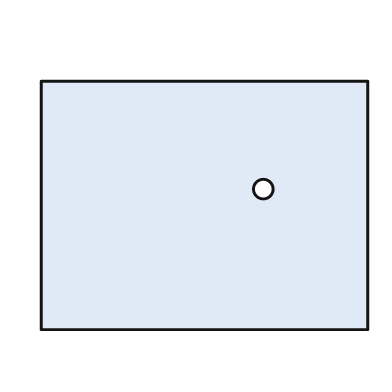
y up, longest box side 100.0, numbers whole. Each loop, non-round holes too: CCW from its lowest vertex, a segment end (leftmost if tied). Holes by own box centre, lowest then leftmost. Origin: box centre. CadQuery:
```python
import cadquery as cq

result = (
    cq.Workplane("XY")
    .moveTo(-50.0, -38.0)
    .lineTo(50.0, -38.0)
    .lineTo(50.0, 38.0)
    .lineTo(-50.0, 38.0)
    .close()
    .moveTo(18.0, 5.0)
    .circle(3.0)
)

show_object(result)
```